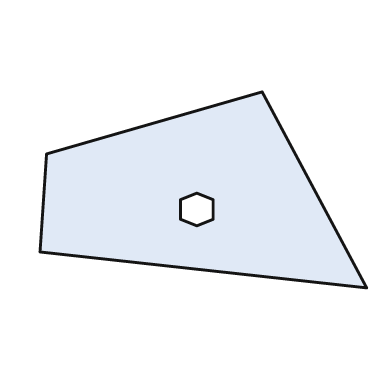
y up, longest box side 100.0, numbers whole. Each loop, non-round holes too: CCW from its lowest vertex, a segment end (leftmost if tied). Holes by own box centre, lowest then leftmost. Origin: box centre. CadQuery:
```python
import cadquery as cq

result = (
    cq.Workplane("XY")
    .moveTo(50.0, -30.0)
    .lineTo(18.0, 30.0)
    .lineTo(-48.0, 11.0)
    .lineTo(-50.0, -19.0)
    .close()
    .moveTo(-2.0, -11.0)
    .lineTo(3.0, -9.0)
    .lineTo(3.0, -3.0)
    .lineTo(-2.0, -1.0)
    .lineTo(-7.0, -3.0)
    .lineTo(-7.0, -9.0)
    .close()
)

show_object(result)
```